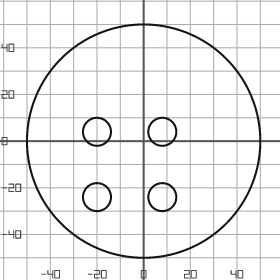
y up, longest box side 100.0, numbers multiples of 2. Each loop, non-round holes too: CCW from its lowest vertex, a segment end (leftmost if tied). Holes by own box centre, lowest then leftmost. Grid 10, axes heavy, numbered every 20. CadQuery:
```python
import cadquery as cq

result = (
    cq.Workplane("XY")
    .moveTo(0.0, 0.0)
    .circle(50.0)
    .moveTo(-20.0, -24.0)
    .circle(6.0)
    .moveTo(8.0, -24.0)
    .circle(6.0)
    .moveTo(-20.0, 4.0)
    .circle(6.0)
    .moveTo(8.0, 4.0)
    .circle(6.0)
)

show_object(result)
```